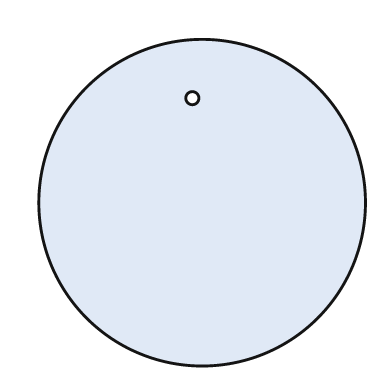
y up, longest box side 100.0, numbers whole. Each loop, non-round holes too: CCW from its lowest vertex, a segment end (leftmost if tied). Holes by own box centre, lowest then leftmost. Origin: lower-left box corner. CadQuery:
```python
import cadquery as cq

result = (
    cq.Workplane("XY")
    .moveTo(50.0, 50.0)
    .circle(50.0)
    .moveTo(47.0, 82.0)
    .circle(2.0)
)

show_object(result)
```